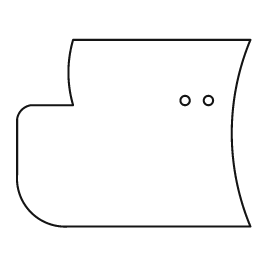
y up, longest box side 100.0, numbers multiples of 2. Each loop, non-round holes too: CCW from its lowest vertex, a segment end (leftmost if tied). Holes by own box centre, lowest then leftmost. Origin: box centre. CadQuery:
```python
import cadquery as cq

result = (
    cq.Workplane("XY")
    .moveTo(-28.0, -40.0)
    .lineTo(50.0, -40.0)
    .threePointArc((42.0, 0.0), (50.0, 40.0))
    .lineTo(-26.0, 40.0)
    .threePointArc((-28.0, 26.0), (-26.0, 12.0))
    .lineTo(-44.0, 12.0)
    .threePointArc((-48.0, 10.0), (-50.0, 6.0))
    .lineTo(-50.0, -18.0)
    .threePointArc((-44.0, -34.0), (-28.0, -40.0))
    .close()
    .moveTo(22.0, 14.0)
    .circle(2.0)
    .moveTo(32.0, 14.0)
    .circle(2.0)
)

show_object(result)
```